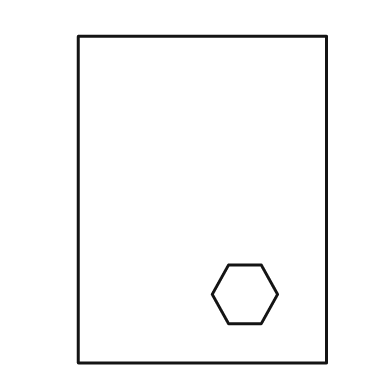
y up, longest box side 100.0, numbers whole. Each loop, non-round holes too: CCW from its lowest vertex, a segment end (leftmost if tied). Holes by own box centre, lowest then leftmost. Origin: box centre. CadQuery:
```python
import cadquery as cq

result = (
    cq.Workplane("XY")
    .moveTo(-38.0, -50.0)
    .lineTo(38.0, -50.0)
    .lineTo(38.0, 50.0)
    .lineTo(-38.0, 50.0)
    .close()
    .moveTo(8.0, -38.0)
    .lineTo(18.0, -38.0)
    .lineTo(23.0, -29.0)
    .lineTo(18.0, -20.0)
    .lineTo(8.0, -20.0)
    .lineTo(3.0, -29.0)
    .close()
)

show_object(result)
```